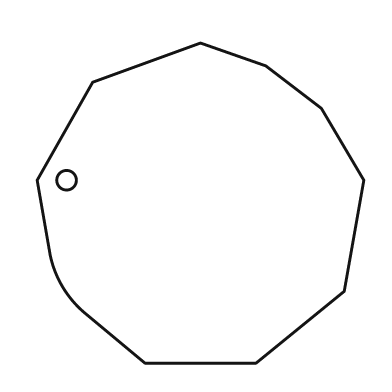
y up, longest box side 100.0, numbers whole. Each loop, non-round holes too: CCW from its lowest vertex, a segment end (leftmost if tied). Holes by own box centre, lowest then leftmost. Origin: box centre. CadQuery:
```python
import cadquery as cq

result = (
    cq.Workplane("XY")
    .moveTo(-17.0, -49.0)
    .lineTo(17.0, -49.0)
    .lineTo(44.0, -27.0)
    .lineTo(50.0, 7.0)
    .lineTo(37.0, 29.0)
    .lineTo(20.0, 42.0)
    .lineTo(0.0, 49.0)
    .lineTo(-33.0, 37.0)
    .lineTo(-50.0, 7.0)
    .lineTo(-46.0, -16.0)
    .threePointArc((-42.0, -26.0), (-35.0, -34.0))
    .close()
    .moveTo(-41.0, 7.0)
    .circle(3.0)
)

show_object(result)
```